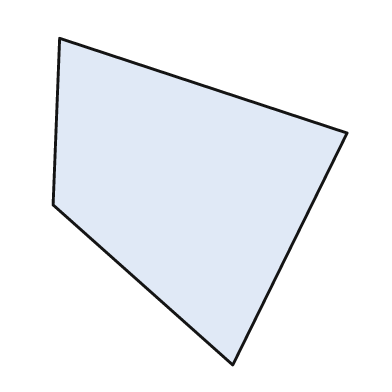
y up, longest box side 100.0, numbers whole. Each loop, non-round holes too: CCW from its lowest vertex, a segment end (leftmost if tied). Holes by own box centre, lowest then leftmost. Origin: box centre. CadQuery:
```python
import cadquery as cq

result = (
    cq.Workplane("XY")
    .moveTo(10.0, -50.0)
    .lineTo(45.0, 21.0)
    .lineTo(-43.0, 50.0)
    .lineTo(-45.0, -1.0)
    .close()
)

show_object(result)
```